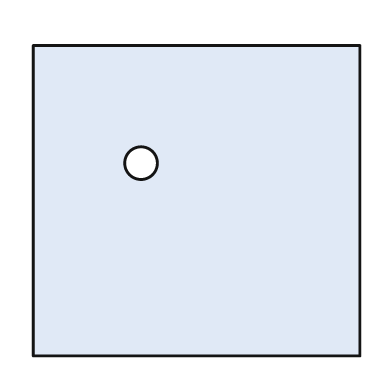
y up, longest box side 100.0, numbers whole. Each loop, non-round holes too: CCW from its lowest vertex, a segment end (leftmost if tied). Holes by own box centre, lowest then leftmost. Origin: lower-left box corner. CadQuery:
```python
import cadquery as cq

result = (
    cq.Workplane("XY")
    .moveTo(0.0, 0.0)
    .lineTo(100.0, 0.0)
    .lineTo(100.0, 95.0)
    .lineTo(0.0, 95.0)
    .close()
    .moveTo(33.0, 59.0)
    .circle(5.0)
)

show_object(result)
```